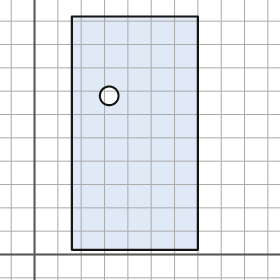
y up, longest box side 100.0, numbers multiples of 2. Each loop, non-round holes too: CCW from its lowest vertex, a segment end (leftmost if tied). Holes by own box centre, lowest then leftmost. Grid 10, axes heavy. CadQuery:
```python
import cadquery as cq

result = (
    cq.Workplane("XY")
    .moveTo(16.0, 2.0)
    .lineTo(70.0, 2.0)
    .lineTo(70.0, 102.0)
    .lineTo(16.0, 102.0)
    .close()
    .moveTo(32.0, 68.0)
    .circle(4.0)
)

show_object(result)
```